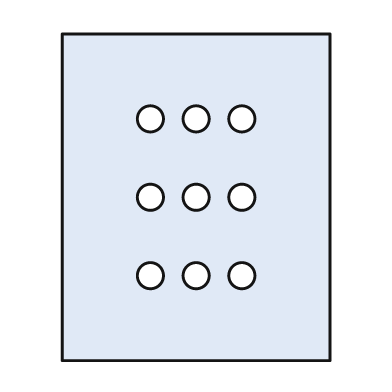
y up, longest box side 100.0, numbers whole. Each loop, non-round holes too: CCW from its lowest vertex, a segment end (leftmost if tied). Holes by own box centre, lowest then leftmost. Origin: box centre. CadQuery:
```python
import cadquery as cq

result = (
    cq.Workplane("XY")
    .moveTo(-41.0, -50.0)
    .lineTo(41.0, -50.0)
    .lineTo(41.0, 50.0)
    .lineTo(-41.0, 50.0)
    .close()
    .moveTo(-14.0, -24.0)
    .circle(4.0)
    .moveTo(0.0, -24.0)
    .circle(4.0)
    .moveTo(14.0, -24.0)
    .circle(4.0)
    .moveTo(-14.0, 0.0)
    .circle(4.0)
    .moveTo(0.0, 0.0)
    .circle(4.0)
    .moveTo(14.0, 0.0)
    .circle(4.0)
    .moveTo(-14.0, 24.0)
    .circle(4.0)
    .moveTo(0.0, 24.0)
    .circle(4.0)
    .moveTo(14.0, 24.0)
    .circle(4.0)
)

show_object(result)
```